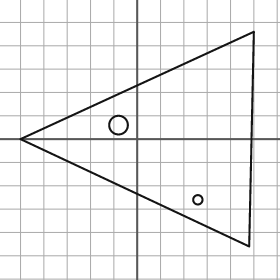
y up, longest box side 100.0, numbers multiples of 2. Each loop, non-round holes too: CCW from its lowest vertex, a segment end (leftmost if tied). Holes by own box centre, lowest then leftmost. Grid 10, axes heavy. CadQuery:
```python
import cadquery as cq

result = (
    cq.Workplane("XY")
    .moveTo(48.0, -46.0)
    .lineTo(50.0, 46.0)
    .lineTo(-50.0, 0.0)
    .close()
    .moveTo(26.0, -26.0)
    .circle(2.0)
    .moveTo(-8.0, 6.0)
    .circle(4.0)
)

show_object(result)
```